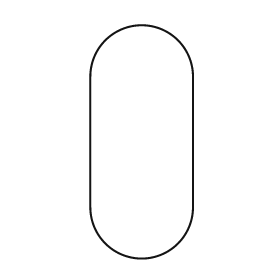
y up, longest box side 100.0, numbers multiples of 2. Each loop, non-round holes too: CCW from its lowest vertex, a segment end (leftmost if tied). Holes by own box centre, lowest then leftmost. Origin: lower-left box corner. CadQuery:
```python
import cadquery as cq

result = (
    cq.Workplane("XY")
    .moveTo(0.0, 22.0)
    .threePointArc((22.0, 0.0), (44.0, 22.0))
    .lineTo(44.0, 78.0)
    .threePointArc((22.0, 100.0), (0.0, 78.0))
    .close()
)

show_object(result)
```